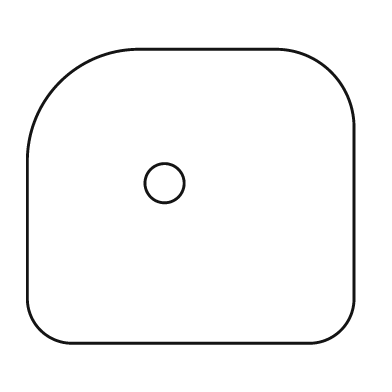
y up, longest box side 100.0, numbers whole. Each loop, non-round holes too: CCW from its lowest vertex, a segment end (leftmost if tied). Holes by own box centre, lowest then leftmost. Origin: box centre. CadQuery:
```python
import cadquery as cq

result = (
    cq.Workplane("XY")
    .moveTo(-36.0, -45.0)
    .lineTo(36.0, -45.0)
    .threePointArc((46.0, -41.0), (50.0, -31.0))
    .lineTo(50.0, 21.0)
    .threePointArc((43.0, 38.0), (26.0, 45.0))
    .lineTo(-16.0, 45.0)
    .threePointArc((-40.0, 35.0), (-50.0, 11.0))
    .lineTo(-50.0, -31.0)
    .threePointArc((-46.0, -41.0), (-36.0, -45.0))
    .close()
    .moveTo(-8.0, 4.0)
    .circle(6.0)
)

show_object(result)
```